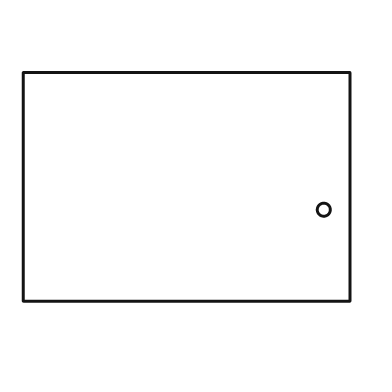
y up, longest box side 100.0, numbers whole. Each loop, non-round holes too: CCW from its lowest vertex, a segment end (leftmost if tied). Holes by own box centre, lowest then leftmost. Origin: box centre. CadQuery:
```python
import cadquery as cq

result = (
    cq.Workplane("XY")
    .moveTo(-50.0, -35.0)
    .lineTo(50.0, -35.0)
    .lineTo(50.0, 35.0)
    .lineTo(-50.0, 35.0)
    .close()
    .moveTo(42.0, -7.0)
    .circle(2.0)
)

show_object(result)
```